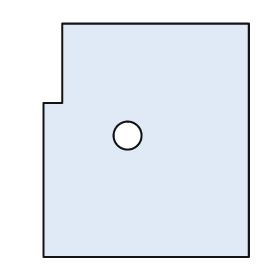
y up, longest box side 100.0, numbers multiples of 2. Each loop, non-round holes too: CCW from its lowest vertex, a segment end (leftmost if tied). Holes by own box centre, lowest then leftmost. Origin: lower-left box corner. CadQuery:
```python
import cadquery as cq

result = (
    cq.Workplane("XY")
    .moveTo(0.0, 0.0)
    .lineTo(88.0, 0.0)
    .lineTo(88.0, 100.0)
    .lineTo(8.0, 100.0)
    .lineTo(8.0, 66.0)
    .lineTo(0.0, 66.0)
    .close()
    .moveTo(36.0, 52.0)
    .circle(6.0)
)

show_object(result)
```